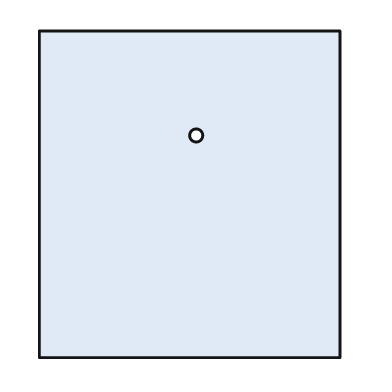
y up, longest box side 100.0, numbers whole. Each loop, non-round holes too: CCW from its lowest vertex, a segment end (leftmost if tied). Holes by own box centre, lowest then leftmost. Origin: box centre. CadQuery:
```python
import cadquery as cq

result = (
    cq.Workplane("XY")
    .moveTo(-46.0, -50.0)
    .lineTo(46.0, -50.0)
    .lineTo(46.0, 50.0)
    .lineTo(-46.0, 50.0)
    .close()
    .moveTo(2.0, 18.0)
    .circle(2.0)
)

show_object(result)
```